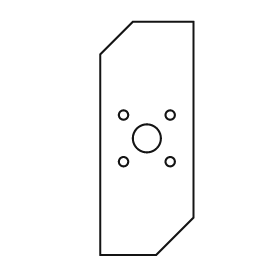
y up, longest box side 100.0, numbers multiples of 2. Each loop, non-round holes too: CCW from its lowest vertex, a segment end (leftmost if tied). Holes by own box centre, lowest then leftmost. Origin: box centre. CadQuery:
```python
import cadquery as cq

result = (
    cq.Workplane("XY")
    .moveTo(-20.0, -50.0)
    .lineTo(4.0, -50.0)
    .lineTo(20.0, -34.0)
    .lineTo(20.0, 50.0)
    .lineTo(-6.0, 50.0)
    .lineTo(-20.0, 36.0)
    .close()
    .moveTo(-10.0, -10.0)
    .circle(2.0)
    .moveTo(10.0, -10.0)
    .circle(2.0)
    .moveTo(0.0, 0.0)
    .circle(6.0)
    .moveTo(-10.0, 10.0)
    .circle(2.0)
    .moveTo(10.0, 10.0)
    .circle(2.0)
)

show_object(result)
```